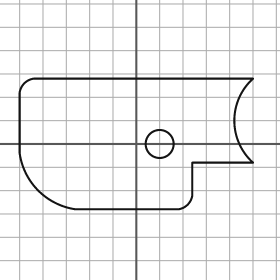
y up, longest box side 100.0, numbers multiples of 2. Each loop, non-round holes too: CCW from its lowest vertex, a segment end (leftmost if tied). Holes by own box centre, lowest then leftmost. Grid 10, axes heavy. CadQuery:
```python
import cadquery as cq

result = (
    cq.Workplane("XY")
    .moveTo(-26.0, -28.0)
    .lineTo(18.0, -28.0)
    .threePointArc((22.0, -26.0), (24.0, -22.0))
    .lineTo(24.0, -8.0)
    .lineTo(50.0, -8.0)
    .threePointArc((42.0, 10.0), (50.0, 28.0))
    .lineTo(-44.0, 28.0)
    .threePointArc((-48.0, 26.0), (-50.0, 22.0))
    .lineTo(-50.0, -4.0)
    .threePointArc((-42.0, -20.0), (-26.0, -28.0))
    .close()
    .moveTo(10.0, 0.0)
    .circle(6.0)
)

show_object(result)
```